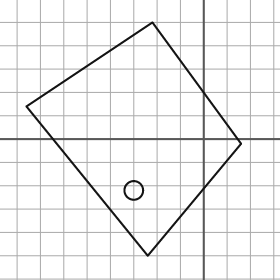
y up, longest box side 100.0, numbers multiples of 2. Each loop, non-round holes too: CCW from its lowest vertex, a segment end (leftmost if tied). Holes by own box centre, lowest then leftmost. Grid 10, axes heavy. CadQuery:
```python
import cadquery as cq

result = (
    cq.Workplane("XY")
    .moveTo(-24.0, -50.0)
    .lineTo(16.0, -2.0)
    .lineTo(-22.0, 50.0)
    .lineTo(-76.0, 14.0)
    .close()
    .moveTo(-30.0, -22.0)
    .circle(4.0)
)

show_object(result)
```